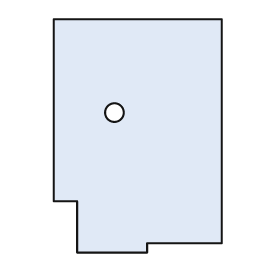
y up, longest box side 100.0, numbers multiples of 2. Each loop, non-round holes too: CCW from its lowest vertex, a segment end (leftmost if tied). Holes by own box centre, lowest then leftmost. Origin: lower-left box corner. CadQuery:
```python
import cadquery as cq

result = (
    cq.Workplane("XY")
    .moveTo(10.0, 0.0)
    .lineTo(40.0, 0.0)
    .lineTo(40.0, 4.0)
    .lineTo(72.0, 4.0)
    .lineTo(72.0, 100.0)
    .lineTo(0.0, 100.0)
    .lineTo(0.0, 22.0)
    .lineTo(10.0, 22.0)
    .close()
    .moveTo(26.0, 60.0)
    .circle(4.0)
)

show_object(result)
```